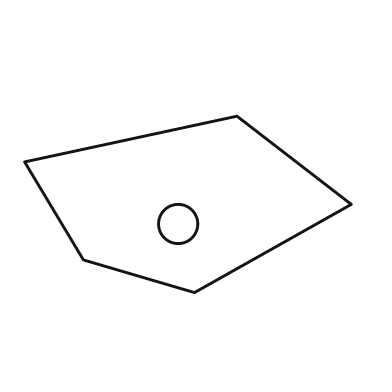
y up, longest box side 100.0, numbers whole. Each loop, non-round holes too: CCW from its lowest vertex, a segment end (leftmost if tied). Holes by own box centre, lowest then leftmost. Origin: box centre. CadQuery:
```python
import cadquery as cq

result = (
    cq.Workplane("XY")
    .moveTo(2.0, -27.0)
    .lineTo(50.0, 0.0)
    .lineTo(15.0, 27.0)
    .lineTo(-50.0, 13.0)
    .lineTo(-32.0, -17.0)
    .close()
    .moveTo(-3.0, -6.0)
    .circle(6.0)
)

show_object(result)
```